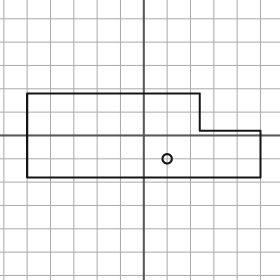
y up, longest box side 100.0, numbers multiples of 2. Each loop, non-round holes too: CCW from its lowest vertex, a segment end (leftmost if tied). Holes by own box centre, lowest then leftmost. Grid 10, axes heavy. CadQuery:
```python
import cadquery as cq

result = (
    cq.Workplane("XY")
    .moveTo(-50.0, -18.0)
    .lineTo(50.0, -18.0)
    .lineTo(50.0, 2.0)
    .lineTo(24.0, 2.0)
    .lineTo(24.0, 18.0)
    .lineTo(-50.0, 18.0)
    .close()
    .moveTo(10.0, -10.0)
    .circle(2.0)
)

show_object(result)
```